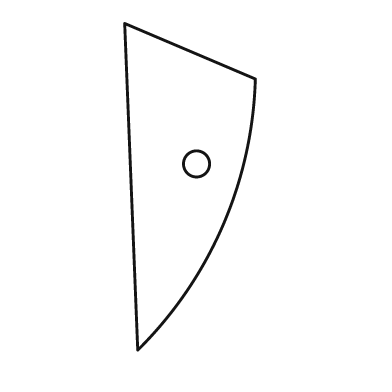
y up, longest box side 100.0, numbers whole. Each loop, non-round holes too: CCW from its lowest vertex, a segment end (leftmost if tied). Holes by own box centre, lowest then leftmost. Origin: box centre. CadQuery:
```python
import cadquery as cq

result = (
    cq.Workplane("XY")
    .moveTo(-16.0, -50.0)
    .threePointArc((10.0, -12.0), (20.0, 33.0))
    .lineTo(-20.0, 50.0)
    .close()
    .moveTo(2.0, 7.0)
    .circle(4.0)
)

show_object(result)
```